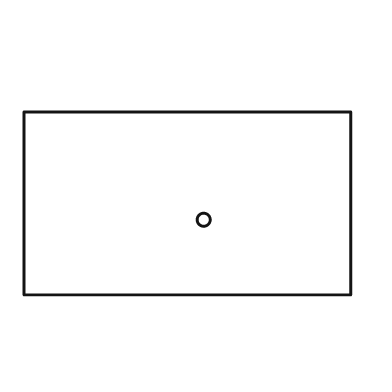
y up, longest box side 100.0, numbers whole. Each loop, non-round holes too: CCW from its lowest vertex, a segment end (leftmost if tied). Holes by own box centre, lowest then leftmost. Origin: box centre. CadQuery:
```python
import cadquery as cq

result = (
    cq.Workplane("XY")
    .moveTo(-50.0, -28.0)
    .lineTo(50.0, -28.0)
    .lineTo(50.0, 28.0)
    .lineTo(-50.0, 28.0)
    .close()
    .moveTo(5.0, -5.0)
    .circle(2.0)
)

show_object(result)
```